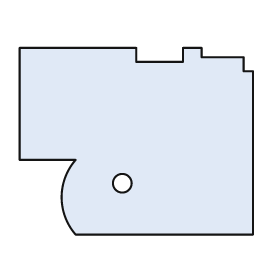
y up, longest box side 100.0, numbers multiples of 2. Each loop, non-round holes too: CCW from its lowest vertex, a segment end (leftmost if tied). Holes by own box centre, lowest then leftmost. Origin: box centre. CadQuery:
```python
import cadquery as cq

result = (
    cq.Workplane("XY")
    .moveTo(-26.0, -40.0)
    .lineTo(50.0, -40.0)
    .lineTo(50.0, 30.0)
    .lineTo(46.0, 30.0)
    .lineTo(46.0, 36.0)
    .lineTo(28.0, 36.0)
    .lineTo(28.0, 40.0)
    .lineTo(20.0, 40.0)
    .lineTo(20.0, 34.0)
    .lineTo(0.0, 34.0)
    .lineTo(0.0, 40.0)
    .lineTo(-50.0, 40.0)
    .lineTo(-50.0, -8.0)
    .lineTo(-26.0, -8.0)
    .threePointArc((-32.0, -24.0), (-26.0, -40.0))
    .close()
    .moveTo(-6.0, -18.0)
    .circle(4.0)
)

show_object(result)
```